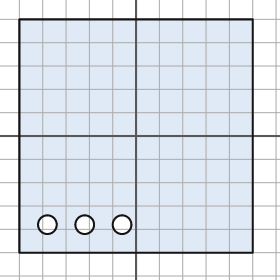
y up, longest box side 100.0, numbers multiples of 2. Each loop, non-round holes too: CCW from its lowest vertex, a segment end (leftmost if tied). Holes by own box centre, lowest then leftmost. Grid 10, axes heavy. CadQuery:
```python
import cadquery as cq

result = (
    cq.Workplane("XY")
    .moveTo(-50.0, -50.0)
    .lineTo(50.0, -50.0)
    .lineTo(50.0, 50.0)
    .lineTo(-50.0, 50.0)
    .close()
    .moveTo(-38.0, -38.0)
    .circle(4.0)
    .moveTo(-22.0, -38.0)
    .circle(4.0)
    .moveTo(-6.0, -38.0)
    .circle(4.0)
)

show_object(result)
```